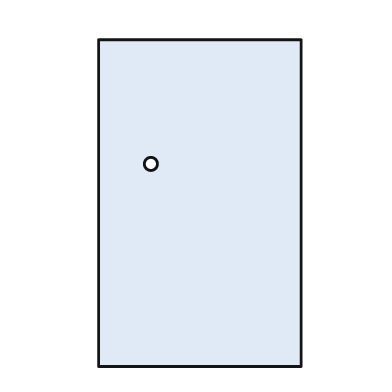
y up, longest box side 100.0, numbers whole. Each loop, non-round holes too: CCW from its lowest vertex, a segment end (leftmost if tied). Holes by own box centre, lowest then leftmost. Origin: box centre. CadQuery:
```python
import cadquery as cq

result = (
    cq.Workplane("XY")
    .moveTo(-31.0, -50.0)
    .lineTo(31.0, -50.0)
    .lineTo(31.0, 50.0)
    .lineTo(-31.0, 50.0)
    .close()
    .moveTo(-15.0, 12.0)
    .circle(2.0)
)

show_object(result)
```